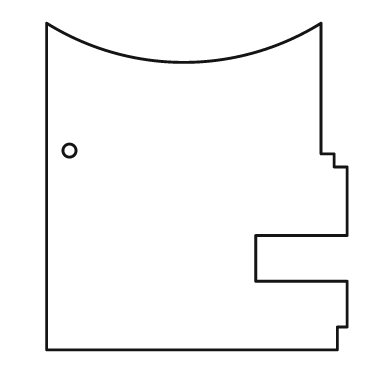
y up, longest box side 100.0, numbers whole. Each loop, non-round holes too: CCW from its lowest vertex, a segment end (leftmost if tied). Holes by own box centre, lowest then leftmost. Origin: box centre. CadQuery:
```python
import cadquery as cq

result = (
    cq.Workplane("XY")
    .moveTo(-46.0, -50.0)
    .lineTo(43.0, -50.0)
    .lineTo(43.0, -43.0)
    .lineTo(46.0, -43.0)
    .lineTo(46.0, -29.0)
    .lineTo(18.0, -29.0)
    .lineTo(18.0, -15.0)
    .lineTo(46.0, -15.0)
    .lineTo(46.0, 6.0)
    .lineTo(42.0, 6.0)
    .lineTo(42.0, 10.0)
    .lineTo(38.0, 10.0)
    .lineTo(38.0, 50.0)
    .threePointArc((-4.0, 38.0), (-46.0, 50.0))
    .close()
    .moveTo(-39.0, 11.0)
    .circle(2.0)
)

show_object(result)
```